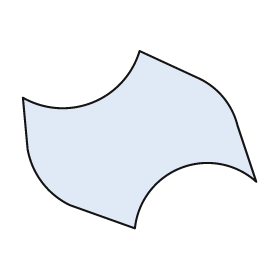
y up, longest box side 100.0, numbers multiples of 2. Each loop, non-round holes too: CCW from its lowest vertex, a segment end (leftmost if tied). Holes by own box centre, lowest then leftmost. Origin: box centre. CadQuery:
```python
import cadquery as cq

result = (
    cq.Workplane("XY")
    .moveTo(-2.0, -38.0)
    .threePointArc((18.0, -12.0), (50.0, -18.0))
    .lineTo(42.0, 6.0)
    .threePointArc((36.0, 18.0), (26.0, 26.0))
    .lineTo(0.0, 38.0)
    .threePointArc((-20.0, 16.0), (-50.0, 18.0))
    .lineTo(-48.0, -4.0)
    .threePointArc((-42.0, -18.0), (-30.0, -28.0))
    .close()
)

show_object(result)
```